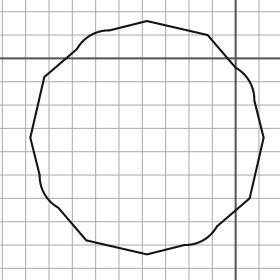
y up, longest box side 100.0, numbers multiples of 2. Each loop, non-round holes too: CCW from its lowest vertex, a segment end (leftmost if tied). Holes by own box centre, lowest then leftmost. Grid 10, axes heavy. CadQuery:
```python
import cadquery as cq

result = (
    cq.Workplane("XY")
    .moveTo(-38.0, -84.0)
    .lineTo(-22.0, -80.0)
    .threePointArc((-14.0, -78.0), (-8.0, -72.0))
    .lineTo(6.0, -60.0)
    .lineTo(12.0, -34.0)
    .lineTo(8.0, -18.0)
    .threePointArc((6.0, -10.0), (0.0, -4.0))
    .lineTo(-12.0, 10.0)
    .lineTo(-38.0, 16.0)
    .lineTo(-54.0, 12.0)
    .threePointArc((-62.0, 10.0), (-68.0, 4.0))
    .lineTo(-82.0, -8.0)
    .lineTo(-88.0, -34.0)
    .lineTo(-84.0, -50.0)
    .threePointArc((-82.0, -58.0), (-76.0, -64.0))
    .lineTo(-64.0, -78.0)
    .close()
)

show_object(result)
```